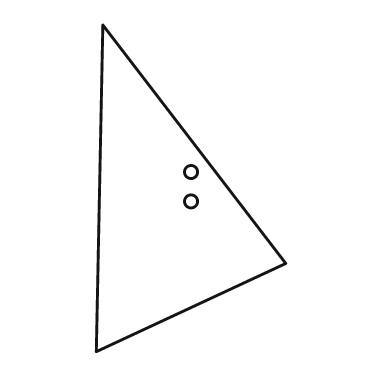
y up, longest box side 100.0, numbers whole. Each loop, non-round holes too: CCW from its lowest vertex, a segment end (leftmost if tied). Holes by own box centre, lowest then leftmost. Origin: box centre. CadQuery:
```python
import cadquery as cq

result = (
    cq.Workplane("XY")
    .moveTo(-29.0, -50.0)
    .lineTo(29.0, -23.0)
    .lineTo(-27.0, 50.0)
    .close()
    .moveTo(0.0, -4.0)
    .circle(2.0)
    .moveTo(0.0, 5.0)
    .circle(2.0)
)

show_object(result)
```